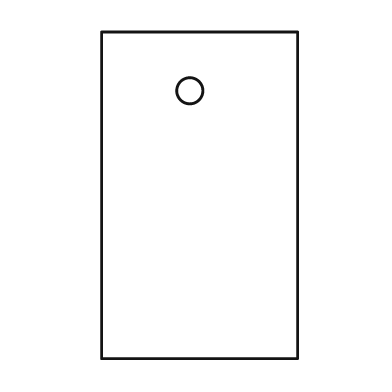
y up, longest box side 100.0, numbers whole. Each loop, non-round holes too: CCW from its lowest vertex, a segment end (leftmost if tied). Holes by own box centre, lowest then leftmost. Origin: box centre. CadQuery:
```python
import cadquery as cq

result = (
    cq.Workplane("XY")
    .moveTo(-30.0, -50.0)
    .lineTo(30.0, -50.0)
    .lineTo(30.0, 50.0)
    .lineTo(-30.0, 50.0)
    .close()
    .moveTo(-3.0, 32.0)
    .circle(4.0)
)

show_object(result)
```